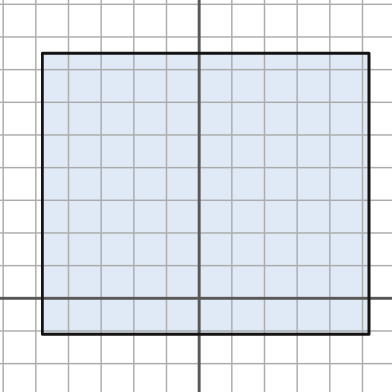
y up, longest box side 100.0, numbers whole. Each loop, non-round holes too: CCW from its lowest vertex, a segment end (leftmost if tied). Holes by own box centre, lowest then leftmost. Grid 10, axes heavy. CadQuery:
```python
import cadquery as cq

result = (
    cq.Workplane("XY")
    .moveTo(-48.0, -11.0)
    .lineTo(52.0, -11.0)
    .lineTo(52.0, 75.0)
    .lineTo(-48.0, 75.0)
    .close()
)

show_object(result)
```